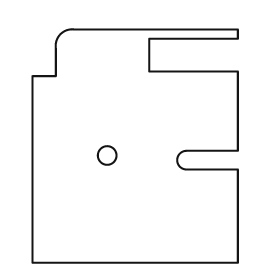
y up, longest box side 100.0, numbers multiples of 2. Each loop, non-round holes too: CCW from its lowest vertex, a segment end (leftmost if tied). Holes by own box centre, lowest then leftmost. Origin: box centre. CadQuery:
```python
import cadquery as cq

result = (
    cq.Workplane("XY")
    .moveTo(-44.0, -50.0)
    .lineTo(44.0, -50.0)
    .lineTo(44.0, -10.0)
    .lineTo(22.0, -10.0)
    .threePointArc((18.0, -6.0), (22.0, -2.0))
    .lineTo(44.0, -2.0)
    .lineTo(44.0, 32.0)
    .lineTo(6.0, 32.0)
    .lineTo(6.0, 46.0)
    .lineTo(44.0, 46.0)
    .lineTo(44.0, 50.0)
    .lineTo(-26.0, 50.0)
    .threePointArc((-32.0, 48.0), (-34.0, 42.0))
    .lineTo(-34.0, 30.0)
    .lineTo(-44.0, 30.0)
    .close()
    .moveTo(-12.0, -4.0)
    .circle(4.0)
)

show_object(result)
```